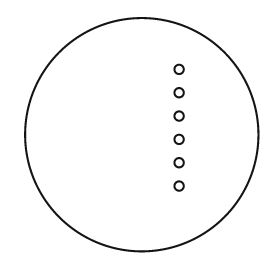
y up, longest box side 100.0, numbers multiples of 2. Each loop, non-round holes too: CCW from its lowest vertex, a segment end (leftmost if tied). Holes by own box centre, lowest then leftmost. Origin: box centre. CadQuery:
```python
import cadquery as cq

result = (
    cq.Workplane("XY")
    .moveTo(0.0, 0.0)
    .circle(50.0)
    .moveTo(16.0, -22.0)
    .circle(2.0)
    .moveTo(16.0, -12.0)
    .circle(2.0)
    .moveTo(16.0, -2.0)
    .circle(2.0)
    .moveTo(16.0, 8.0)
    .circle(2.0)
    .moveTo(16.0, 18.0)
    .circle(2.0)
    .moveTo(16.0, 28.0)
    .circle(2.0)
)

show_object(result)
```